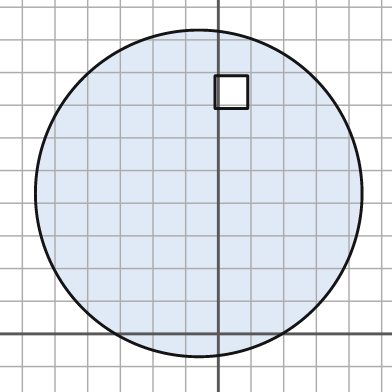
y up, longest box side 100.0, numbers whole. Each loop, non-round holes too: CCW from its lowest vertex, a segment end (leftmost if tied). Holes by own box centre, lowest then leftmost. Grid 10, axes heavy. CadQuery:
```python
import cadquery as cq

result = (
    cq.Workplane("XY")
    .moveTo(-6.0, 43.0)
    .circle(50.0)
    .moveTo(-1.0, 69.0)
    .lineTo(9.0, 69.0)
    .lineTo(9.0, 79.0)
    .lineTo(-1.0, 79.0)
    .close()
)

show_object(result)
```